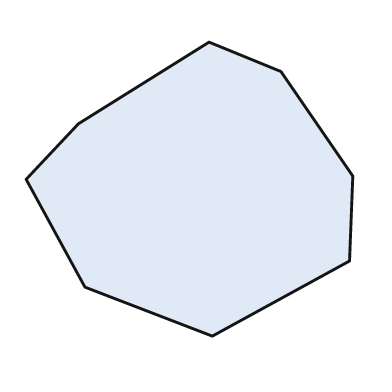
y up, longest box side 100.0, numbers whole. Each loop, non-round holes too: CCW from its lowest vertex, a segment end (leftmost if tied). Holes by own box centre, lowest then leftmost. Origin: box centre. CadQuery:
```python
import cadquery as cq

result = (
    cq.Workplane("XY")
    .moveTo(7.0, -45.0)
    .lineTo(49.0, -22.0)
    .lineTo(50.0, 4.0)
    .lineTo(28.0, 36.0)
    .lineTo(6.0, 45.0)
    .lineTo(-34.0, 20.0)
    .lineTo(-50.0, 3.0)
    .lineTo(-32.0, -30.0)
    .close()
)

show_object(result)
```